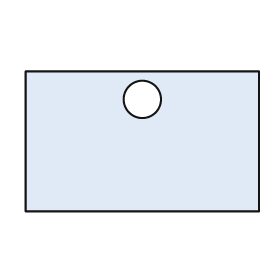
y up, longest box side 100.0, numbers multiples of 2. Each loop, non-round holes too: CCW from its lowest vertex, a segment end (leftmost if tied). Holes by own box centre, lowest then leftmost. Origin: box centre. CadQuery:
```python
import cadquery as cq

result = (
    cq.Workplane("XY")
    .moveTo(-50.0, -30.0)
    .lineTo(50.0, -30.0)
    .lineTo(50.0, 30.0)
    .lineTo(-50.0, 30.0)
    .close()
    .moveTo(0.0, 18.0)
    .circle(8.0)
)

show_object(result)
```